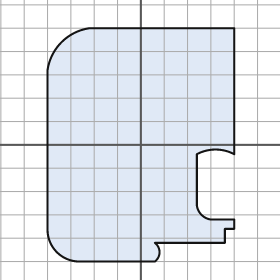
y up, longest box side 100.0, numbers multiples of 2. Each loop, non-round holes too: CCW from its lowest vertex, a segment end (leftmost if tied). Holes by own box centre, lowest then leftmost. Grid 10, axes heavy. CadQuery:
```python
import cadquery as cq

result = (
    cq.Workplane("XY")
    .moveTo(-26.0, -50.0)
    .lineTo(6.0, -50.0)
    .threePointArc((8.0, -46.0), (6.0, -42.0))
    .lineTo(36.0, -42.0)
    .lineTo(36.0, -36.0)
    .lineTo(40.0, -36.0)
    .lineTo(40.0, -32.0)
    .lineTo(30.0, -32.0)
    .threePointArc((26.0, -30.0), (24.0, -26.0))
    .lineTo(24.0, -4.0)
    .threePointArc((32.0, -2.0), (40.0, -4.0))
    .lineTo(40.0, 50.0)
    .lineTo(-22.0, 50.0)
    .threePointArc((-34.0, 44.0), (-40.0, 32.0))
    .lineTo(-40.0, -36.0)
    .threePointArc((-36.0, -46.0), (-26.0, -50.0))
    .close()
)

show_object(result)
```